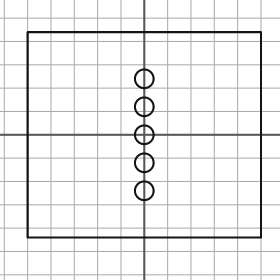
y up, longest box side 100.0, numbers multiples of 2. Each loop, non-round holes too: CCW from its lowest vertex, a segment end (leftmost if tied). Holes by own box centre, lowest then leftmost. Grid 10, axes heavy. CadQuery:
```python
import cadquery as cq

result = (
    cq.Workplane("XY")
    .moveTo(-50.0, -44.0)
    .lineTo(50.0, -44.0)
    .lineTo(50.0, 44.0)
    .lineTo(-50.0, 44.0)
    .close()
    .moveTo(0.0, -24.0)
    .circle(4.0)
    .moveTo(0.0, -12.0)
    .circle(4.0)
    .moveTo(0.0, 0.0)
    .circle(4.0)
    .moveTo(0.0, 12.0)
    .circle(4.0)
    .moveTo(0.0, 24.0)
    .circle(4.0)
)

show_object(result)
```